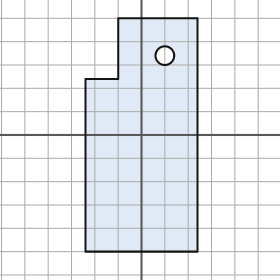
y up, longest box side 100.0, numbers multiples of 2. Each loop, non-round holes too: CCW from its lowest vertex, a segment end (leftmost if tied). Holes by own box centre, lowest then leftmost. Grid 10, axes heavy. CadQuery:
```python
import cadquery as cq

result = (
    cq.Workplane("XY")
    .moveTo(-24.0, -50.0)
    .lineTo(24.0, -50.0)
    .lineTo(24.0, 50.0)
    .lineTo(-10.0, 50.0)
    .lineTo(-10.0, 24.0)
    .lineTo(-24.0, 24.0)
    .close()
    .moveTo(10.0, 34.0)
    .circle(4.0)
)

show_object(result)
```